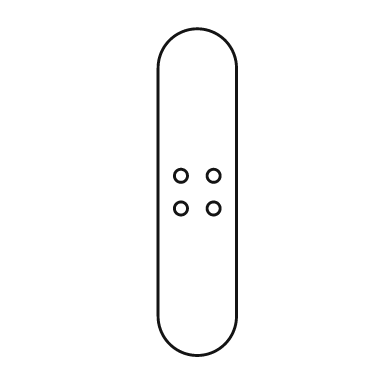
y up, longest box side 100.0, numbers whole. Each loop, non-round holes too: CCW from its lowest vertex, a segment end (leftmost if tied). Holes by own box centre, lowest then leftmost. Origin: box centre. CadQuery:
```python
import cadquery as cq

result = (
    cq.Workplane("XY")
    .moveTo(-12.0, -38.0)
    .threePointArc((0.0, -50.0), (12.0, -38.0))
    .lineTo(12.0, 38.0)
    .threePointArc((0.0, 50.0), (-12.0, 38.0))
    .close()
    .moveTo(-5.0, -5.0)
    .circle(2.0)
    .moveTo(5.0, -5.0)
    .circle(2.0)
    .moveTo(-5.0, 5.0)
    .circle(2.0)
    .moveTo(5.0, 5.0)
    .circle(2.0)
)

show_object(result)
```